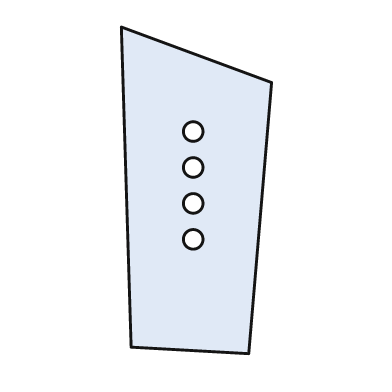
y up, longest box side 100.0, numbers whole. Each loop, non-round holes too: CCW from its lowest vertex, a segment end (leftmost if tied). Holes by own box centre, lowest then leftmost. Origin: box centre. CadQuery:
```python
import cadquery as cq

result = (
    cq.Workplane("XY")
    .moveTo(16.0, -50.0)
    .lineTo(23.0, 33.0)
    .lineTo(-23.0, 50.0)
    .lineTo(-20.0, -48.0)
    .close()
    .moveTo(-1.0, -15.0)
    .circle(3.0)
    .moveTo(-1.0, -4.0)
    .circle(3.0)
    .moveTo(-1.0, 7.0)
    .circle(3.0)
    .moveTo(-1.0, 18.0)
    .circle(3.0)
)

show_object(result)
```